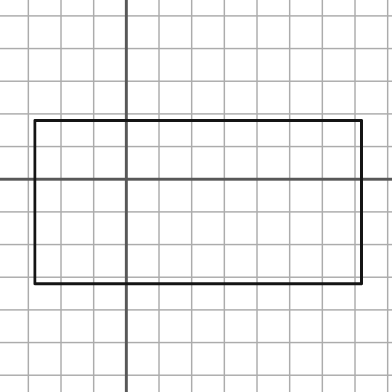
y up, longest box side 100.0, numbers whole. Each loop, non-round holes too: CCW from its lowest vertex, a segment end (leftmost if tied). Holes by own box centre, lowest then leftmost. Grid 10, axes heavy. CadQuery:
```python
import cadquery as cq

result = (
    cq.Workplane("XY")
    .moveTo(-28.0, -32.0)
    .lineTo(72.0, -32.0)
    .lineTo(72.0, 18.0)
    .lineTo(-28.0, 18.0)
    .close()
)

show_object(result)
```